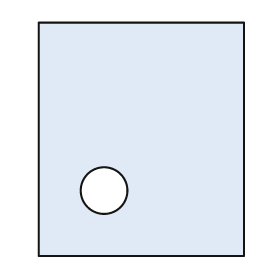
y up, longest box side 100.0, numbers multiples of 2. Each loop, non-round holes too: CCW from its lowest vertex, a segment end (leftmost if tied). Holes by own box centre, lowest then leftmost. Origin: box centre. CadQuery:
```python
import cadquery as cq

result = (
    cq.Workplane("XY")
    .moveTo(-44.0, -50.0)
    .lineTo(44.0, -50.0)
    .lineTo(44.0, 50.0)
    .lineTo(-44.0, 50.0)
    .close()
    .moveTo(-16.0, -22.0)
    .circle(10.0)
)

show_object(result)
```